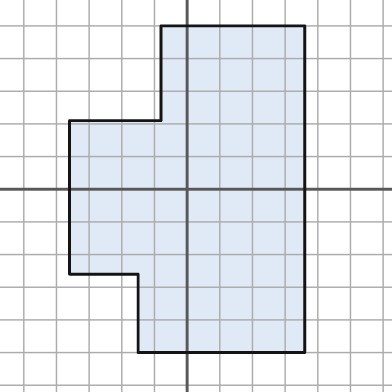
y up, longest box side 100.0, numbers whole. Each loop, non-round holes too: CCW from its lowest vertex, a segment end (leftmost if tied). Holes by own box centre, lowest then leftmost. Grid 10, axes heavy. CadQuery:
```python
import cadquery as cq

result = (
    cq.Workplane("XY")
    .moveTo(-15.0, -50.0)
    .lineTo(36.0, -50.0)
    .lineTo(36.0, 50.0)
    .lineTo(-8.0, 50.0)
    .lineTo(-8.0, 21.0)
    .lineTo(-36.0, 21.0)
    .lineTo(-36.0, -26.0)
    .lineTo(-15.0, -26.0)
    .close()
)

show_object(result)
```